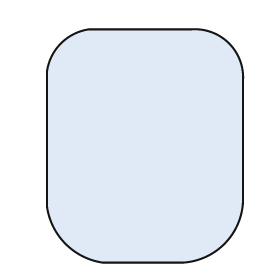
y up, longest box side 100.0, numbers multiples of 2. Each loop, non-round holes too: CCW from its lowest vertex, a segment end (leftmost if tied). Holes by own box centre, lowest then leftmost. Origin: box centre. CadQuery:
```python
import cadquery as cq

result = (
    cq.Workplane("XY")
    .moveTo(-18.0, -50.0)
    .lineTo(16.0, -50.0)
    .threePointArc((34.0, -42.0), (42.0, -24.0))
    .lineTo(42.0, 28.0)
    .threePointArc((36.0, 44.0), (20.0, 50.0))
    .lineTo(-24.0, 50.0)
    .threePointArc((-36.0, 44.0), (-42.0, 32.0))
    .lineTo(-42.0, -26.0)
    .threePointArc((-34.0, -42.0), (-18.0, -50.0))
    .close()
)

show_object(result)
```